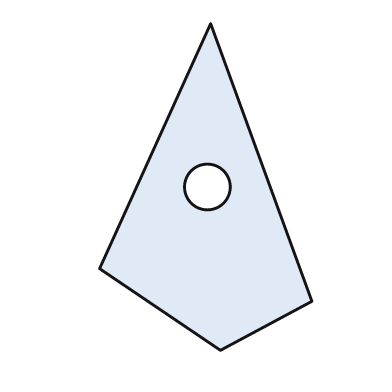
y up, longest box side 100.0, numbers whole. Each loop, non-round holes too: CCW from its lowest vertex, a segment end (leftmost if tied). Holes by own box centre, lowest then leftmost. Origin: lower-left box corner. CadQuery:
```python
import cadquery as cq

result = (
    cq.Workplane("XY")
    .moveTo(37.0, 0.0)
    .lineTo(65.0, 15.0)
    .lineTo(34.0, 100.0)
    .lineTo(0.0, 25.0)
    .close()
    .moveTo(33.0, 50.0)
    .circle(7.0)
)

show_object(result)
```